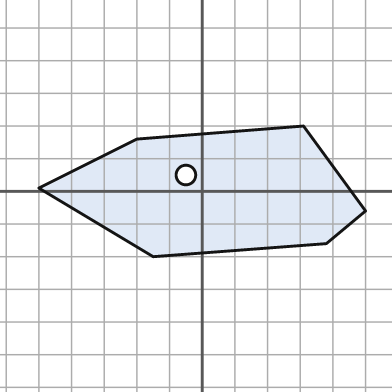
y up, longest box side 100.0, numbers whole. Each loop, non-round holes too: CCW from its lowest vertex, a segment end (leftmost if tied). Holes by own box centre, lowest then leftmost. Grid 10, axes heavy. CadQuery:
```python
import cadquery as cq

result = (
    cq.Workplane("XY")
    .moveTo(-15.0, -20.0)
    .lineTo(38.0, -16.0)
    .lineTo(50.0, -6.0)
    .lineTo(31.0, 20.0)
    .lineTo(-20.0, 16.0)
    .lineTo(-50.0, 1.0)
    .close()
    .moveTo(-5.0, 5.0)
    .circle(3.0)
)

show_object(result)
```